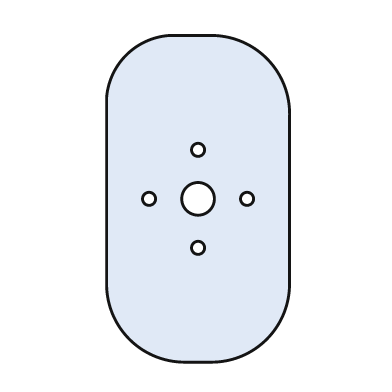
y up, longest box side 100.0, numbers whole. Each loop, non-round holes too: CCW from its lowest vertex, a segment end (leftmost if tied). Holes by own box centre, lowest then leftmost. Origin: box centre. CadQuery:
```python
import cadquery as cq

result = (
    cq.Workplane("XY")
    .moveTo(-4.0, -50.0)
    .lineTo(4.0, -50.0)
    .threePointArc((21.0, -43.0), (28.0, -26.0))
    .lineTo(28.0, 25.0)
    .threePointArc((21.0, 43.0), (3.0, 50.0))
    .lineTo(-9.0, 50.0)
    .threePointArc((-22.0, 44.0), (-28.0, 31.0))
    .lineTo(-28.0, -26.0)
    .threePointArc((-21.0, -43.0), (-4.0, -50.0))
    .close()
    .moveTo(0.0, -15.0)
    .circle(2.0)
    .moveTo(-15.0, 0.0)
    .circle(2.0)
    .moveTo(0.0, 0.0)
    .circle(5.0)
    .moveTo(15.0, 0.0)
    .circle(2.0)
    .moveTo(0.0, 15.0)
    .circle(2.0)
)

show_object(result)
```